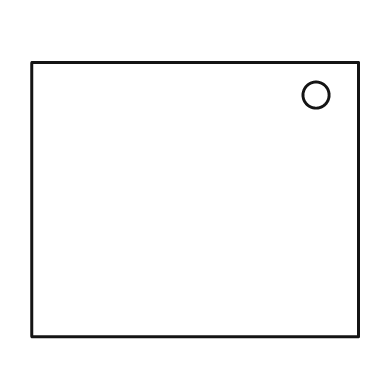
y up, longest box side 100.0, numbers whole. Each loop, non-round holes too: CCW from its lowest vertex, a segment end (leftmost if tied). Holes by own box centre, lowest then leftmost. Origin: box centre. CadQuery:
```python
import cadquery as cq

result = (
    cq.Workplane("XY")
    .moveTo(-50.0, -42.0)
    .lineTo(50.0, -42.0)
    .lineTo(50.0, 42.0)
    .lineTo(-50.0, 42.0)
    .close()
    .moveTo(37.0, 32.0)
    .circle(4.0)
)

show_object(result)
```